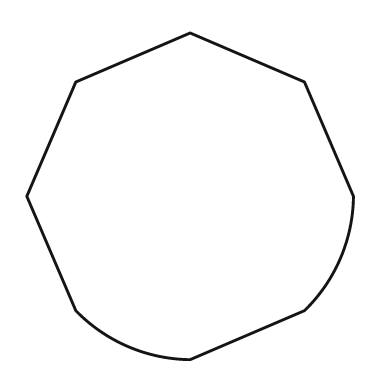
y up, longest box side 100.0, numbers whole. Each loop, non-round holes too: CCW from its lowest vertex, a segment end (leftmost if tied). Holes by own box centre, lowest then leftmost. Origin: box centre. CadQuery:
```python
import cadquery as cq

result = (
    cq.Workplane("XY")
    .moveTo(0.0, -50.0)
    .lineTo(35.0, -35.0)
    .threePointArc((46.0, -19.0), (50.0, 0.0))
    .lineTo(35.0, 35.0)
    .lineTo(0.0, 50.0)
    .lineTo(-35.0, 35.0)
    .lineTo(-50.0, 0.0)
    .lineTo(-35.0, -35.0)
    .threePointArc((-19.0, -46.0), (0.0, -50.0))
    .close()
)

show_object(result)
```